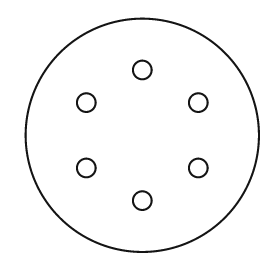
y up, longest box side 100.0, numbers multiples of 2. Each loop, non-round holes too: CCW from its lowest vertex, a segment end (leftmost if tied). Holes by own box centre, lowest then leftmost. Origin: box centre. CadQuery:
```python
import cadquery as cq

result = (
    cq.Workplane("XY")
    .moveTo(0.0, 0.0)
    .circle(50.0)
    .moveTo(0.0, -28.0)
    .circle(4.0)
    .moveTo(-24.0, -14.0)
    .circle(4.0)
    .moveTo(24.0, -14.0)
    .circle(4.0)
    .moveTo(-24.0, 14.0)
    .circle(4.0)
    .moveTo(24.0, 14.0)
    .circle(4.0)
    .moveTo(0.0, 28.0)
    .circle(4.0)
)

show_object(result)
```